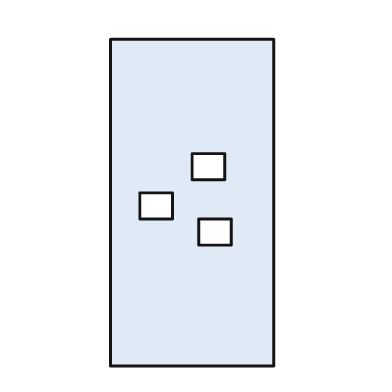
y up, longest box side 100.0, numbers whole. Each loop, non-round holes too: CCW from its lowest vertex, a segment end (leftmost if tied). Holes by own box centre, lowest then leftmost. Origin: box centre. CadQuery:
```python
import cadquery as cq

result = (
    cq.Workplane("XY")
    .moveTo(-25.0, -50.0)
    .lineTo(25.0, -50.0)
    .lineTo(25.0, 50.0)
    .lineTo(-25.0, 50.0)
    .close()
    .moveTo(2.0, -13.0)
    .lineTo(12.0, -13.0)
    .lineTo(12.0, -5.0)
    .lineTo(2.0, -5.0)
    .close()
    .moveTo(-16.0, -5.0)
    .lineTo(-6.0, -5.0)
    .lineTo(-6.0, 3.0)
    .lineTo(-16.0, 3.0)
    .close()
    .moveTo(0.0, 7.0)
    .lineTo(10.0, 7.0)
    .lineTo(10.0, 15.0)
    .lineTo(0.0, 15.0)
    .close()
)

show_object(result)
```